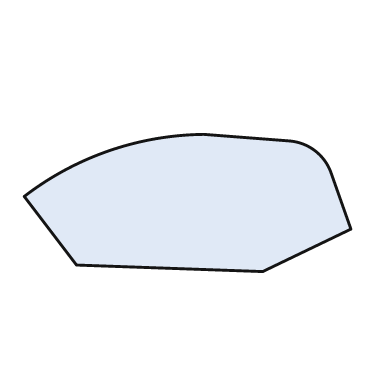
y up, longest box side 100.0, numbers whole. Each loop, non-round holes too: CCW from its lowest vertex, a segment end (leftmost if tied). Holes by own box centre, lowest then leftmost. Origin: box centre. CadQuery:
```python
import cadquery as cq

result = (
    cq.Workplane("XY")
    .moveTo(23.0, -21.0)
    .lineTo(50.0, -8.0)
    .lineTo(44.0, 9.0)
    .threePointArc((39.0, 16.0), (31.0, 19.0))
    .lineTo(5.0, 21.0)
    .threePointArc((-24.0, 16.0), (-50.0, 2.0))
    .lineTo(-34.0, -19.0)
    .close()
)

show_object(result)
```